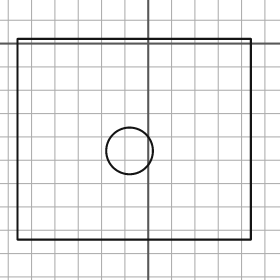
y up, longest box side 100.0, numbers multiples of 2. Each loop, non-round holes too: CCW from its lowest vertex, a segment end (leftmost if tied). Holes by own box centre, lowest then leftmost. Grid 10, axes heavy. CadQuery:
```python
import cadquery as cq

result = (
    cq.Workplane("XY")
    .moveTo(-56.0, -84.0)
    .lineTo(44.0, -84.0)
    .lineTo(44.0, 2.0)
    .lineTo(-56.0, 2.0)
    .close()
    .moveTo(-8.0, -46.0)
    .circle(10.0)
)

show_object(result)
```